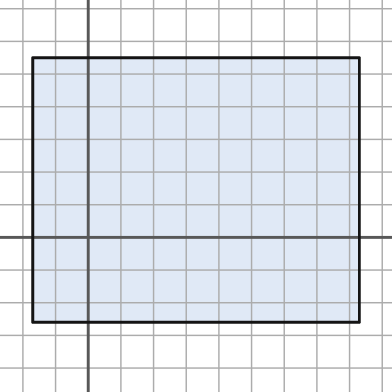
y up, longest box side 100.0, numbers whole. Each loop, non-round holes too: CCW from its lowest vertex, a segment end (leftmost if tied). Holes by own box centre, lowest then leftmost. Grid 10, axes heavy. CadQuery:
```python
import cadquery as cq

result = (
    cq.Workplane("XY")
    .moveTo(-17.0, -26.0)
    .lineTo(83.0, -26.0)
    .lineTo(83.0, 55.0)
    .lineTo(-17.0, 55.0)
    .close()
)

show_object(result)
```